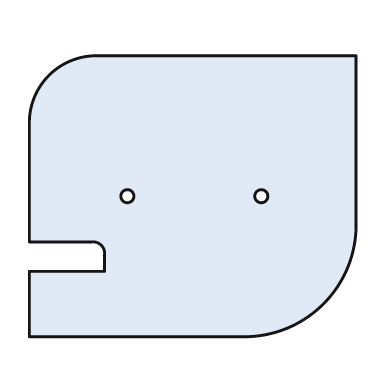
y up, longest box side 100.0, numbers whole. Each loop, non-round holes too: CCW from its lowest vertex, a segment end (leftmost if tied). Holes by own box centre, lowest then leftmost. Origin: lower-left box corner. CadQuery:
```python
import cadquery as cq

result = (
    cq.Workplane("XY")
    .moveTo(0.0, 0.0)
    .lineTo(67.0, 0.0)
    .threePointArc((90.0, 10.0), (100.0, 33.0))
    .lineTo(100.0, 86.0)
    .lineTo(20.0, 86.0)
    .threePointArc((6.0, 80.0), (0.0, 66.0))
    .lineTo(0.0, 29.0)
    .lineTo(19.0, 29.0)
    .threePointArc((22.0, 28.0), (23.0, 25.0))
    .lineTo(23.0, 20.0)
    .lineTo(0.0, 20.0)
    .close()
    .moveTo(30.0, 43.0)
    .circle(2.0)
    .moveTo(71.0, 43.0)
    .circle(2.0)
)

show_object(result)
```